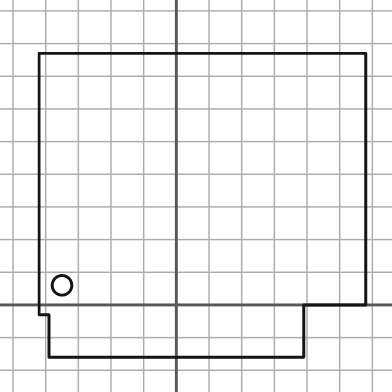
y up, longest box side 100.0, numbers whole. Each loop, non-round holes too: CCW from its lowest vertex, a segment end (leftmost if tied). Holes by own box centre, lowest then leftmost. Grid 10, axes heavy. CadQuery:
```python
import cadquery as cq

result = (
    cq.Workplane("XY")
    .moveTo(-39.0, -16.0)
    .lineTo(39.0, -16.0)
    .lineTo(39.0, 0.0)
    .lineTo(58.0, 0.0)
    .lineTo(58.0, 77.0)
    .lineTo(-42.0, 77.0)
    .lineTo(-42.0, -3.0)
    .lineTo(-39.0, -3.0)
    .close()
    .moveTo(-35.0, 6.0)
    .circle(3.0)
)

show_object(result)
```